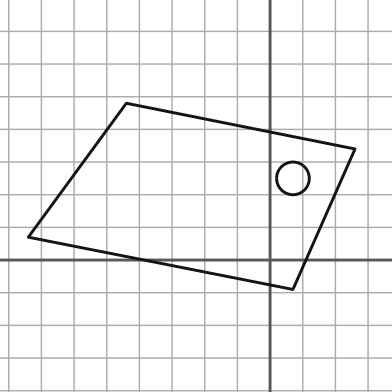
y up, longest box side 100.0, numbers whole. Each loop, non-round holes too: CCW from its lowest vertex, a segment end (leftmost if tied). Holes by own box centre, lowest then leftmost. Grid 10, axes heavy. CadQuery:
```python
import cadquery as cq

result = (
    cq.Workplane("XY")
    .moveTo(7.0, -9.0)
    .lineTo(26.0, 34.0)
    .lineTo(-44.0, 48.0)
    .lineTo(-74.0, 7.0)
    .close()
    .moveTo(7.0, 25.0)
    .circle(5.0)
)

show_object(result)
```